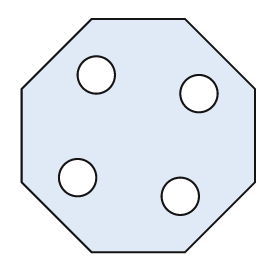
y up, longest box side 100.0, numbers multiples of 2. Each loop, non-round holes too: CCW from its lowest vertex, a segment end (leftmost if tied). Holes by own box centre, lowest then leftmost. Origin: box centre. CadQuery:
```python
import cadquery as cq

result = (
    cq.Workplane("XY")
    .moveTo(-20.0, -50.0)
    .lineTo(20.0, -50.0)
    .lineTo(50.0, -20.0)
    .lineTo(50.0, 20.0)
    .lineTo(20.0, 50.0)
    .lineTo(-20.0, 50.0)
    .lineTo(-50.0, 20.0)
    .lineTo(-50.0, -20.0)
    .close()
    .moveTo(18.0, -26.0)
    .circle(8.0)
    .moveTo(-26.0, -18.0)
    .circle(8.0)
    .moveTo(26.0, 18.0)
    .circle(8.0)
    .moveTo(-18.0, 26.0)
    .circle(8.0)
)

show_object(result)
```